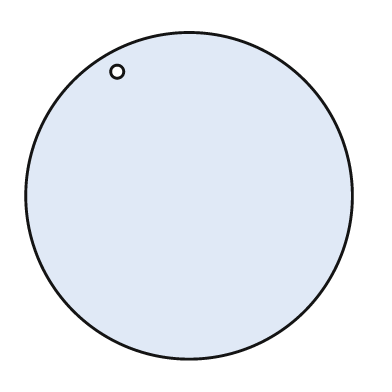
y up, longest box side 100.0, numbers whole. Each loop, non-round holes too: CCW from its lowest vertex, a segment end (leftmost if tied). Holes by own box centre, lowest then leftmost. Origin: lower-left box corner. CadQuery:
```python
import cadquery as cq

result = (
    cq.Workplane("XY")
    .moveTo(50.0, 50.0)
    .circle(50.0)
    .moveTo(28.0, 88.0)
    .circle(2.0)
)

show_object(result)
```